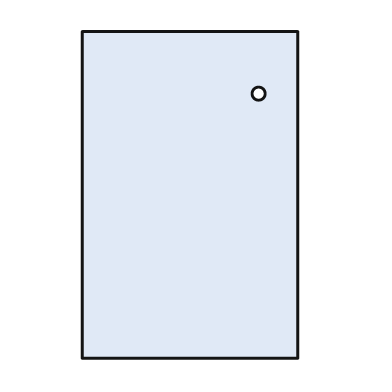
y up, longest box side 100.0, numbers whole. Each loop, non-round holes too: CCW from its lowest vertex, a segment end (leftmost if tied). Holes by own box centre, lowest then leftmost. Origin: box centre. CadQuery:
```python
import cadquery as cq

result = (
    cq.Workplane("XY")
    .moveTo(-33.0, -50.0)
    .lineTo(33.0, -50.0)
    .lineTo(33.0, 50.0)
    .lineTo(-33.0, 50.0)
    .close()
    .moveTo(21.0, 31.0)
    .circle(2.0)
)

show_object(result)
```